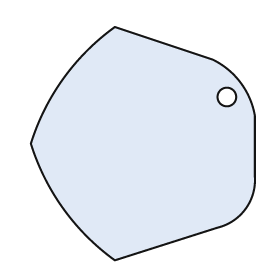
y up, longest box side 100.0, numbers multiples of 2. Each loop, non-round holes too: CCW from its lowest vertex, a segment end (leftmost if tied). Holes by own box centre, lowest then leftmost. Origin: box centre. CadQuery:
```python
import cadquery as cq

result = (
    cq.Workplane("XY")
    .moveTo(-12.0, -50.0)
    .lineTo(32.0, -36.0)
    .threePointArc((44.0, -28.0), (48.0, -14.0))
    .lineTo(48.0, 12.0)
    .threePointArc((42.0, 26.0), (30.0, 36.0))
    .lineTo(-12.0, 50.0)
    .threePointArc((-34.0, 28.0), (-48.0, 0.0))
    .threePointArc((-34.0, -28.0), (-12.0, -50.0))
    .close()
    .moveTo(36.0, 20.0)
    .circle(4.0)
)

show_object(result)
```